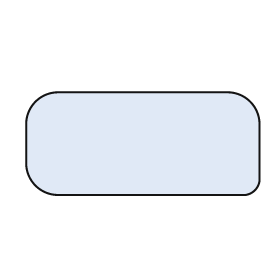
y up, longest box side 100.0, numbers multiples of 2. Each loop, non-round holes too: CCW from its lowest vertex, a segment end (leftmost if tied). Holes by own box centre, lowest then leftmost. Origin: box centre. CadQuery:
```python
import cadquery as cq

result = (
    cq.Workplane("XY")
    .moveTo(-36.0, -22.0)
    .lineTo(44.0, -22.0)
    .threePointArc((48.0, -20.0), (50.0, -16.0))
    .lineTo(50.0, 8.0)
    .threePointArc((46.0, 18.0), (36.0, 22.0))
    .lineTo(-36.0, 22.0)
    .threePointArc((-46.0, 18.0), (-50.0, 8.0))
    .lineTo(-50.0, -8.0)
    .threePointArc((-46.0, -18.0), (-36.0, -22.0))
    .close()
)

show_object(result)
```